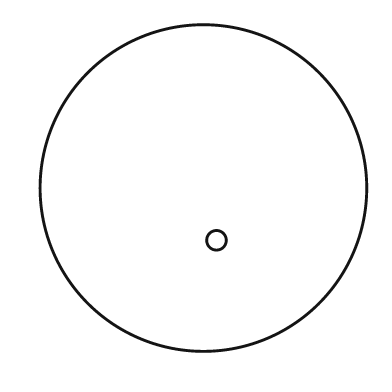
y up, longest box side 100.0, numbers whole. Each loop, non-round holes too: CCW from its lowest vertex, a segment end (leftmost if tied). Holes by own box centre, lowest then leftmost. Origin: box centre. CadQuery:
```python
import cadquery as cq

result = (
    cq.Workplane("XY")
    .moveTo(0.0, 0.0)
    .circle(50.0)
    .moveTo(4.0, -16.0)
    .circle(3.0)
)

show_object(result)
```